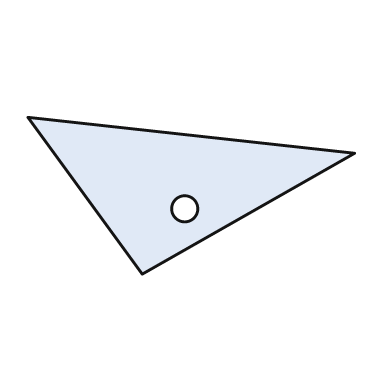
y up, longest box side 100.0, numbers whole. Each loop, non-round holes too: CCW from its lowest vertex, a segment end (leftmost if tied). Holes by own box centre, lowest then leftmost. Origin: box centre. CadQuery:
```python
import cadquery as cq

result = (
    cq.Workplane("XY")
    .moveTo(-15.0, -24.0)
    .lineTo(50.0, 13.0)
    .lineTo(-50.0, 24.0)
    .close()
    .moveTo(-2.0, -4.0)
    .circle(4.0)
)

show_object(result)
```